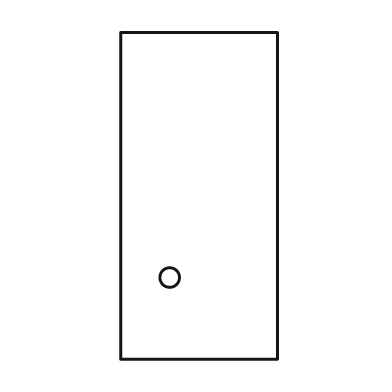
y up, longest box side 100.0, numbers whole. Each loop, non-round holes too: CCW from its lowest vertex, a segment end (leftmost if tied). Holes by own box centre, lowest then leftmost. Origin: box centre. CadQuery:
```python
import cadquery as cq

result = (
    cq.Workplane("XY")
    .moveTo(-24.0, -50.0)
    .lineTo(24.0, -50.0)
    .lineTo(24.0, 50.0)
    .lineTo(-24.0, 50.0)
    .close()
    .moveTo(-9.0, -25.0)
    .circle(3.0)
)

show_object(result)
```